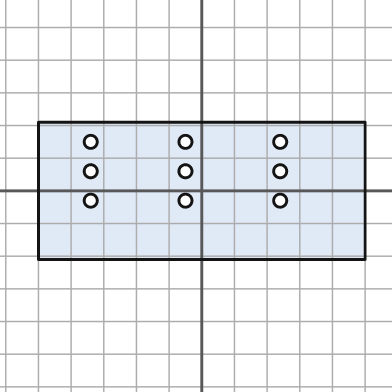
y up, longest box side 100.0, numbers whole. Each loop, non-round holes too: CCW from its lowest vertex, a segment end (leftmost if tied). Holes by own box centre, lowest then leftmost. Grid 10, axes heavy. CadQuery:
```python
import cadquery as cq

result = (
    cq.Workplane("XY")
    .moveTo(-50.0, -21.0)
    .lineTo(50.0, -21.0)
    .lineTo(50.0, 21.0)
    .lineTo(-50.0, 21.0)
    .close()
    .moveTo(-34.0, -3.0)
    .circle(2.0)
    .moveTo(-5.0, -3.0)
    .circle(2.0)
    .moveTo(24.0, -3.0)
    .circle(2.0)
    .moveTo(-34.0, 6.0)
    .circle(2.0)
    .moveTo(-5.0, 6.0)
    .circle(2.0)
    .moveTo(24.0, 6.0)
    .circle(2.0)
    .moveTo(-34.0, 15.0)
    .circle(2.0)
    .moveTo(-5.0, 15.0)
    .circle(2.0)
    .moveTo(24.0, 15.0)
    .circle(2.0)
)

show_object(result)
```